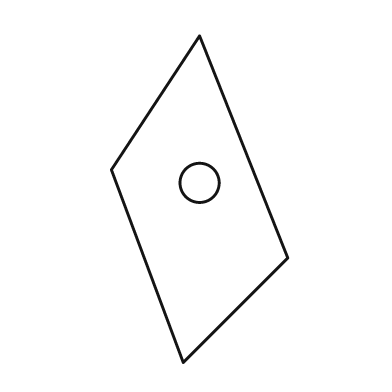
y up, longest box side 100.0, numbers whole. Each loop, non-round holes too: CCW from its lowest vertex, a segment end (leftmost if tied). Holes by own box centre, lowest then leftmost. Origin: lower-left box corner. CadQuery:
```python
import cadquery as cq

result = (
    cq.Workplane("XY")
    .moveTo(22.0, 0.0)
    .lineTo(54.0, 32.0)
    .lineTo(27.0, 100.0)
    .lineTo(0.0, 59.0)
    .close()
    .moveTo(27.0, 55.0)
    .circle(6.0)
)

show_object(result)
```